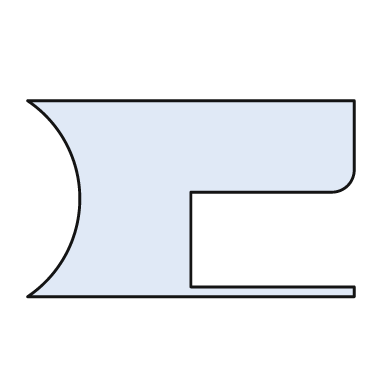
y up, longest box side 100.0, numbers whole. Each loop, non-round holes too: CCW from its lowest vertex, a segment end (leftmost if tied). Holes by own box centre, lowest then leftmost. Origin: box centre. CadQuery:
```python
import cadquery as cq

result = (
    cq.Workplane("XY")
    .moveTo(-50.0, -30.0)
    .lineTo(50.0, -30.0)
    .lineTo(50.0, -27.0)
    .lineTo(0.0, -27.0)
    .lineTo(0.0, 2.0)
    .lineTo(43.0, 2.0)
    .threePointArc((48.0, 4.0), (50.0, 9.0))
    .lineTo(50.0, 30.0)
    .lineTo(-50.0, 30.0)
    .threePointArc((-34.0, 0.0), (-50.0, -30.0))
    .close()
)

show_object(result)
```